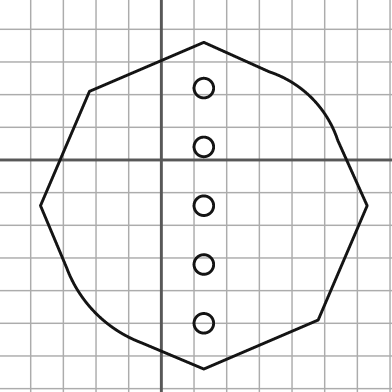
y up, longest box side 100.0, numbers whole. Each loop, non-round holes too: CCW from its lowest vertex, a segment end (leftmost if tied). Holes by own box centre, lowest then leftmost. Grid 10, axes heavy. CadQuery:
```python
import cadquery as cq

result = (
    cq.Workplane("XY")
    .moveTo(13.0, -64.0)
    .lineTo(48.0, -49.0)
    .lineTo(63.0, -14.0)
    .lineTo(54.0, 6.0)
    .threePointArc((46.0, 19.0), (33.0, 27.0))
    .lineTo(13.0, 36.0)
    .lineTo(-22.0, 21.0)
    .lineTo(-37.0, -14.0)
    .lineTo(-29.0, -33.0)
    .threePointArc((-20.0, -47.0), (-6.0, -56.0))
    .close()
    .moveTo(13.0, -50.0)
    .circle(3.0)
    .moveTo(13.0, -32.0)
    .circle(3.0)
    .moveTo(13.0, -14.0)
    .circle(3.0)
    .moveTo(13.0, 4.0)
    .circle(3.0)
    .moveTo(13.0, 22.0)
    .circle(3.0)
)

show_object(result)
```